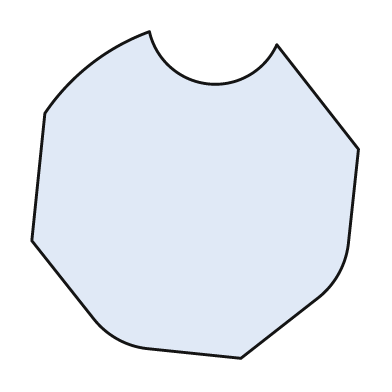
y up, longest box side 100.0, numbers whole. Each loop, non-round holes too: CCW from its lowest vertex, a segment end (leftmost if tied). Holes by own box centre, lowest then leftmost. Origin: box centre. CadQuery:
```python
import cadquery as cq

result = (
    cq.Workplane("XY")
    .moveTo(14.0, -50.0)
    .lineTo(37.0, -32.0)
    .threePointArc((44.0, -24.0), (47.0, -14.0))
    .lineTo(50.0, 14.0)
    .lineTo(25.0, 46.0)
    .threePointArc((4.0, 34.0), (-14.0, 50.0))
    .threePointArc((-32.0, 40.0), (-46.0, 25.0))
    .lineTo(-50.0, -14.0)
    .lineTo(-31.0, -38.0)
    .threePointArc((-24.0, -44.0), (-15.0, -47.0))
    .close()
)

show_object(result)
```